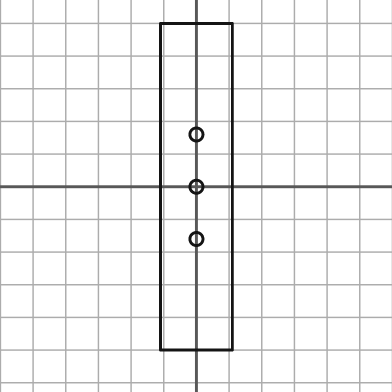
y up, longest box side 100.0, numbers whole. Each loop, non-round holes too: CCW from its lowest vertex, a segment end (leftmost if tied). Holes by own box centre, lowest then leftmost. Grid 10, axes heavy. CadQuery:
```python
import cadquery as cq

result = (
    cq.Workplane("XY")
    .moveTo(-11.0, -50.0)
    .lineTo(11.0, -50.0)
    .lineTo(11.0, 50.0)
    .lineTo(-11.0, 50.0)
    .close()
    .moveTo(0.0, -16.0)
    .circle(2.0)
    .moveTo(0.0, 0.0)
    .circle(2.0)
    .moveTo(0.0, 16.0)
    .circle(2.0)
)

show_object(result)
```